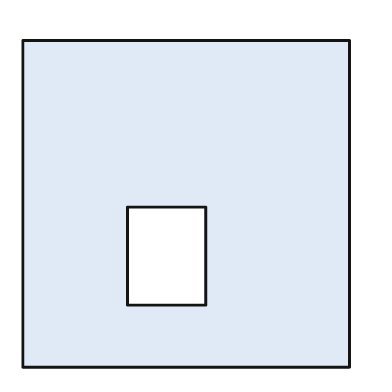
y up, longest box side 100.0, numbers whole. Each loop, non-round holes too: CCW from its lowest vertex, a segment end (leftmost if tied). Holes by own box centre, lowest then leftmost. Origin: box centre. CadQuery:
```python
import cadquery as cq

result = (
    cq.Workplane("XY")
    .moveTo(-50.0, -50.0)
    .lineTo(50.0, -50.0)
    .lineTo(50.0, 50.0)
    .lineTo(-50.0, 50.0)
    .close()
    .moveTo(-18.0, -31.0)
    .lineTo(6.0, -31.0)
    .lineTo(6.0, -1.0)
    .lineTo(-18.0, -1.0)
    .close()
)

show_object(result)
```